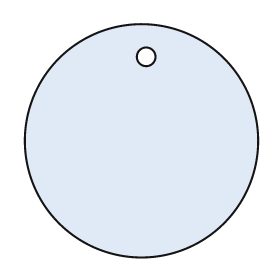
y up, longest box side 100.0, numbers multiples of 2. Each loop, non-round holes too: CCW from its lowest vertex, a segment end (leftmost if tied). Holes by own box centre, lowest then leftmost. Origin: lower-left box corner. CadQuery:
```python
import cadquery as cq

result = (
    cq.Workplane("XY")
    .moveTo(50.0, 50.0)
    .circle(50.0)
    .moveTo(52.0, 86.0)
    .circle(4.0)
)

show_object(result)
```